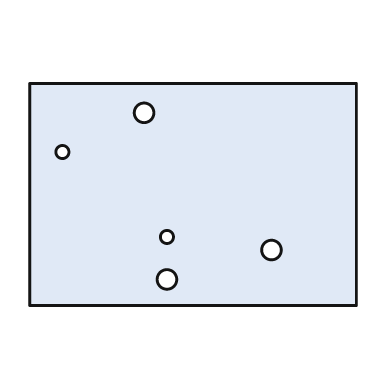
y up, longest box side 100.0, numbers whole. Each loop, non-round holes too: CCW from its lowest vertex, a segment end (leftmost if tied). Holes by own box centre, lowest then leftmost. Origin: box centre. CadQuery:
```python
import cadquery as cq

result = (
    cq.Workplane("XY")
    .moveTo(-50.0, -34.0)
    .lineTo(50.0, -34.0)
    .lineTo(50.0, 34.0)
    .lineTo(-50.0, 34.0)
    .close()
    .moveTo(-8.0, -26.0)
    .circle(3.0)
    .moveTo(24.0, -17.0)
    .circle(3.0)
    .moveTo(-8.0, -13.0)
    .circle(2.0)
    .moveTo(-40.0, 13.0)
    .circle(2.0)
    .moveTo(-15.0, 25.0)
    .circle(3.0)
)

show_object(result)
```